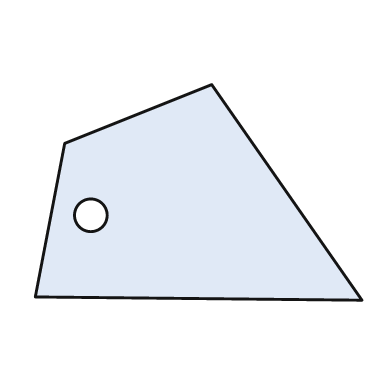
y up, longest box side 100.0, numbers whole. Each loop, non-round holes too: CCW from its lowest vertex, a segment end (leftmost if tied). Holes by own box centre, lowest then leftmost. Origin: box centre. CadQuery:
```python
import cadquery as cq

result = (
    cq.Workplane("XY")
    .moveTo(50.0, -33.0)
    .lineTo(4.0, 33.0)
    .lineTo(-41.0, 15.0)
    .lineTo(-50.0, -32.0)
    .close()
    .moveTo(-33.0, -7.0)
    .circle(5.0)
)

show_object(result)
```